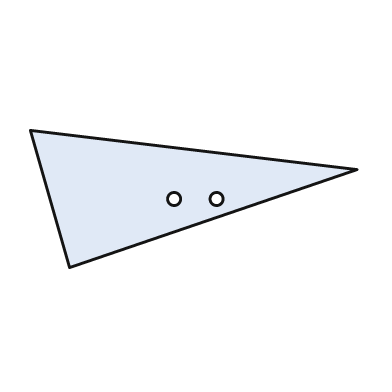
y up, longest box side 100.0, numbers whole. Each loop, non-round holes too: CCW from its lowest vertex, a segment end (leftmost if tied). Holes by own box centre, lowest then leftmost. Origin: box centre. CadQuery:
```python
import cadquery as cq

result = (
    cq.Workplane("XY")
    .moveTo(-38.0, -21.0)
    .lineTo(50.0, 9.0)
    .lineTo(-50.0, 21.0)
    .close()
    .moveTo(-6.0, 0.0)
    .circle(2.0)
    .moveTo(7.0, 0.0)
    .circle(2.0)
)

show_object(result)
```